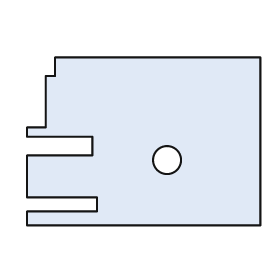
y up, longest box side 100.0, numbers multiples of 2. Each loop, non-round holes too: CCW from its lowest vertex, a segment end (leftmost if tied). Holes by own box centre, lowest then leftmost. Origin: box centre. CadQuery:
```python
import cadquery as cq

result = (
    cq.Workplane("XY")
    .moveTo(-50.0, -36.0)
    .lineTo(50.0, -36.0)
    .lineTo(50.0, 36.0)
    .lineTo(-38.0, 36.0)
    .lineTo(-38.0, 28.0)
    .lineTo(-42.0, 28.0)
    .lineTo(-42.0, 6.0)
    .lineTo(-50.0, 6.0)
    .lineTo(-50.0, 2.0)
    .lineTo(-22.0, 2.0)
    .lineTo(-22.0, -6.0)
    .lineTo(-50.0, -6.0)
    .lineTo(-50.0, -24.0)
    .lineTo(-20.0, -24.0)
    .lineTo(-20.0, -30.0)
    .lineTo(-50.0, -30.0)
    .close()
    .moveTo(10.0, -8.0)
    .circle(6.0)
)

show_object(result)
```